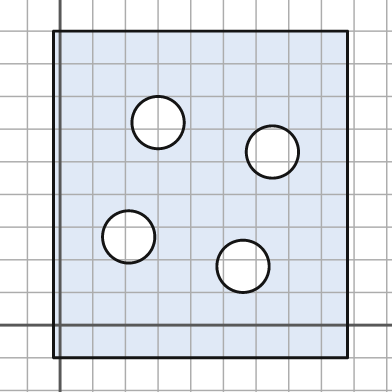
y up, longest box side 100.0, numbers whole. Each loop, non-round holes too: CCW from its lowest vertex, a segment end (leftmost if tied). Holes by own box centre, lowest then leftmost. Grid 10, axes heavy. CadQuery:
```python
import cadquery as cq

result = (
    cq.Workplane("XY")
    .moveTo(-2.0, -10.0)
    .lineTo(88.0, -10.0)
    .lineTo(88.0, 90.0)
    .lineTo(-2.0, 90.0)
    .close()
    .moveTo(56.0, 18.0)
    .circle(8.0)
    .moveTo(21.0, 27.0)
    .circle(8.0)
    .moveTo(65.0, 53.0)
    .circle(8.0)
    .moveTo(30.0, 62.0)
    .circle(8.0)
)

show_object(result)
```